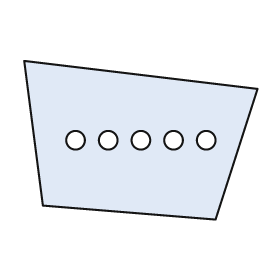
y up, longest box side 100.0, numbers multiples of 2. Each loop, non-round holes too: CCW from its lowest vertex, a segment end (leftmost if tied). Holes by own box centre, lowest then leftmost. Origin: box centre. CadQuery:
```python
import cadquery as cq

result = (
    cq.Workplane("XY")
    .moveTo(32.0, -34.0)
    .lineTo(50.0, 22.0)
    .lineTo(-50.0, 34.0)
    .lineTo(-42.0, -28.0)
    .close()
    .moveTo(-28.0, 0.0)
    .circle(4.0)
    .moveTo(-14.0, 0.0)
    .circle(4.0)
    .moveTo(0.0, 0.0)
    .circle(4.0)
    .moveTo(14.0, 0.0)
    .circle(4.0)
    .moveTo(28.0, 0.0)
    .circle(4.0)
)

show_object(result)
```